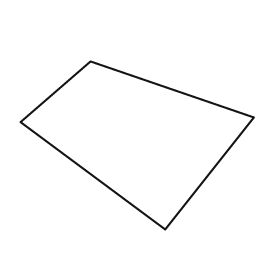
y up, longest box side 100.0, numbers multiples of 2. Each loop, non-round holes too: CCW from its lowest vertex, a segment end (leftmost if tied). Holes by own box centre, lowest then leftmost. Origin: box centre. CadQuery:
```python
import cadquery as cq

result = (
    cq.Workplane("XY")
    .moveTo(12.0, -36.0)
    .lineTo(50.0, 12.0)
    .lineTo(-20.0, 36.0)
    .lineTo(-50.0, 10.0)
    .close()
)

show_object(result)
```